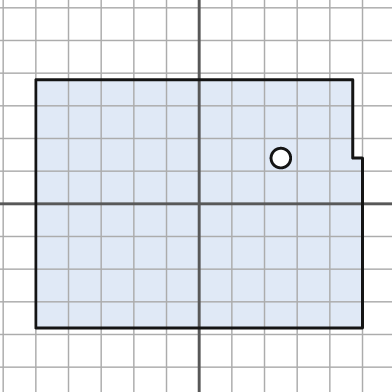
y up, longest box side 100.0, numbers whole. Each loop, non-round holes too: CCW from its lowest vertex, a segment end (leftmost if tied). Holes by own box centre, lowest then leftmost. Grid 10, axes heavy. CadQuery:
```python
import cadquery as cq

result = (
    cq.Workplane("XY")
    .moveTo(-50.0, -38.0)
    .lineTo(50.0, -38.0)
    .lineTo(50.0, 14.0)
    .lineTo(47.0, 14.0)
    .lineTo(47.0, 38.0)
    .lineTo(-50.0, 38.0)
    .close()
    .moveTo(25.0, 14.0)
    .circle(3.0)
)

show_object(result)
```